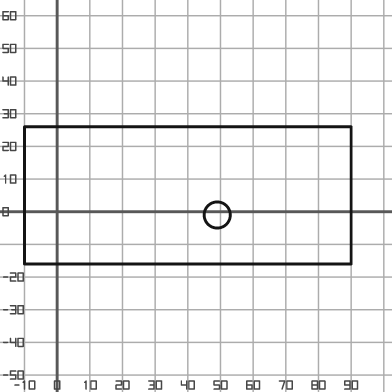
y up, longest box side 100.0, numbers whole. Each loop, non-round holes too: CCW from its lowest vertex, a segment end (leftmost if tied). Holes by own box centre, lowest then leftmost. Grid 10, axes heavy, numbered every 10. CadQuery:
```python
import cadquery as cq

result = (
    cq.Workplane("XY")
    .moveTo(-10.0, -16.0)
    .lineTo(90.0, -16.0)
    .lineTo(90.0, 26.0)
    .lineTo(-10.0, 26.0)
    .close()
    .moveTo(49.0, -1.0)
    .circle(4.0)
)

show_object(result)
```